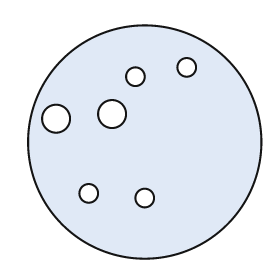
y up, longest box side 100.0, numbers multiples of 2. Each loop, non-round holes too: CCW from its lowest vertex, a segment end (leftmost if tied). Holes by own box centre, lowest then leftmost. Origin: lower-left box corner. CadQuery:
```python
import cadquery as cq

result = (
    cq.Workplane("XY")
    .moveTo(50.0, 50.0)
    .circle(50.0)
    .moveTo(50.0, 26.0)
    .circle(4.0)
    .moveTo(26.0, 28.0)
    .circle(4.0)
    .moveTo(12.0, 60.0)
    .circle(6.0)
    .moveTo(36.0, 62.0)
    .circle(6.0)
    .moveTo(46.0, 78.0)
    .circle(4.0)
    .moveTo(68.0, 82.0)
    .circle(4.0)
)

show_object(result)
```